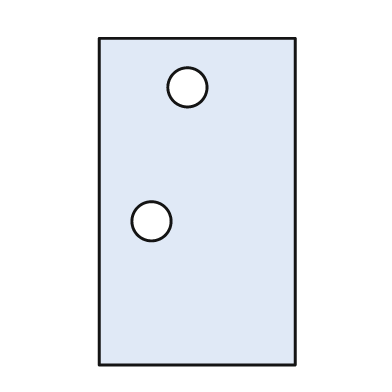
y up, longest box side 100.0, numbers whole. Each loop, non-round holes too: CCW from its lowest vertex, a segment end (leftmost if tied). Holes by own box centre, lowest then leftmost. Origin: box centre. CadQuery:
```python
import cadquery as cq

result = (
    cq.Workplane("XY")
    .moveTo(-30.0, -50.0)
    .lineTo(30.0, -50.0)
    .lineTo(30.0, 50.0)
    .lineTo(-30.0, 50.0)
    .close()
    .moveTo(-14.0, -6.0)
    .circle(6.0)
    .moveTo(-3.0, 35.0)
    .circle(6.0)
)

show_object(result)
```